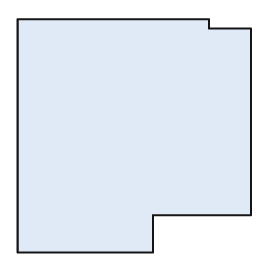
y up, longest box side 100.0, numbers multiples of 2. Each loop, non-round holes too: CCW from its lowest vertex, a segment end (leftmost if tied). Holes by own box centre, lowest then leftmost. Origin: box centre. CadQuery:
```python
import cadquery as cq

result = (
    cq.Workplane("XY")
    .moveTo(-50.0, -50.0)
    .lineTo(8.0, -50.0)
    .lineTo(8.0, -34.0)
    .lineTo(50.0, -34.0)
    .lineTo(50.0, 46.0)
    .lineTo(32.0, 46.0)
    .lineTo(32.0, 50.0)
    .lineTo(-50.0, 50.0)
    .close()
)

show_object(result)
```